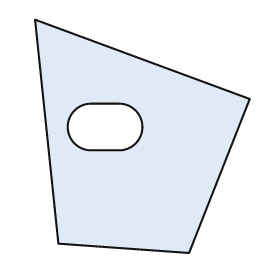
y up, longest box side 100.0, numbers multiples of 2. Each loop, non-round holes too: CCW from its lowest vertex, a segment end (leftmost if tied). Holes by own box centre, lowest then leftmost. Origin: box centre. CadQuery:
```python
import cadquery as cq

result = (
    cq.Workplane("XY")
    .moveTo(20.0, -50.0)
    .lineTo(46.0, 16.0)
    .lineTo(-46.0, 50.0)
    .lineTo(-36.0, -46.0)
    .close()
    .moveTo(-22.0, -6.0)
    .lineTo(-10.0, -6.0)
    .threePointArc((0.0, 4.0), (-10.0, 14.0))
    .lineTo(-22.0, 14.0)
    .threePointArc((-32.0, 4.0), (-22.0, -6.0))
    .close()
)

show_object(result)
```